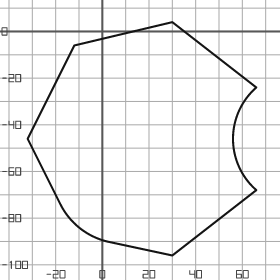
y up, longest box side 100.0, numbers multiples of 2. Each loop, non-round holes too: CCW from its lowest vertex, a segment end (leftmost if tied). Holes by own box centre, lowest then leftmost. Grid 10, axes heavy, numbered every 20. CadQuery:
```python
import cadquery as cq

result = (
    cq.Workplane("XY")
    .moveTo(30.0, -96.0)
    .lineTo(66.0, -68.0)
    .threePointArc((56.0, -46.0), (66.0, -24.0))
    .lineTo(30.0, 4.0)
    .lineTo(-12.0, -6.0)
    .lineTo(-32.0, -46.0)
    .lineTo(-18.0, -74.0)
    .threePointArc((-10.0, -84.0), (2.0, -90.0))
    .close()
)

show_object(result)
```